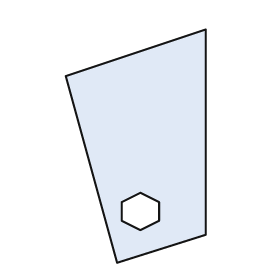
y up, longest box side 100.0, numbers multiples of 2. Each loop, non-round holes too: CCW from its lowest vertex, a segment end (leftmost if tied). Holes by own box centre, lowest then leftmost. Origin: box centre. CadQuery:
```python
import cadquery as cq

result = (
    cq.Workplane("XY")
    .moveTo(-8.0, -50.0)
    .lineTo(30.0, -38.0)
    .lineTo(30.0, 50.0)
    .lineTo(-30.0, 30.0)
    .close()
    .moveTo(2.0, -36.0)
    .lineTo(10.0, -32.0)
    .lineTo(10.0, -24.0)
    .lineTo(2.0, -20.0)
    .lineTo(-6.0, -24.0)
    .lineTo(-6.0, -32.0)
    .close()
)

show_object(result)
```